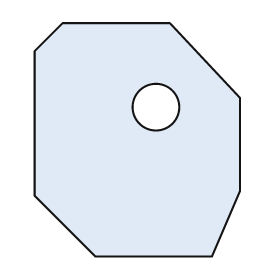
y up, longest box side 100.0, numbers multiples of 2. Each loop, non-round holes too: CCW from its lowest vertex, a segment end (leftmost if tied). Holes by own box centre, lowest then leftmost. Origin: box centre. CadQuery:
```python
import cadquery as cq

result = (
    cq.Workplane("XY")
    .moveTo(-18.0, -50.0)
    .lineTo(32.0, -50.0)
    .lineTo(44.0, -22.0)
    .lineTo(44.0, 18.0)
    .lineTo(14.0, 50.0)
    .lineTo(-32.0, 50.0)
    .lineTo(-44.0, 38.0)
    .lineTo(-44.0, -24.0)
    .close()
    .moveTo(8.0, 14.0)
    .circle(10.0)
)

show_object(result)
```